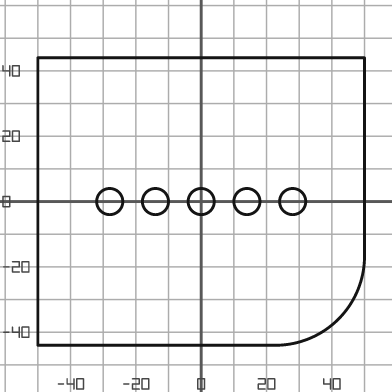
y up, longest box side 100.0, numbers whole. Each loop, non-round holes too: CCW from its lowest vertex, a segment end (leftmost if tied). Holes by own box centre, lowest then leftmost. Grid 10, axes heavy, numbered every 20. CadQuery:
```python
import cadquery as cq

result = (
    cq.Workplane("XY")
    .moveTo(-50.0, -44.0)
    .lineTo(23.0, -44.0)
    .threePointArc((42.0, -36.0), (50.0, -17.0))
    .lineTo(50.0, 44.0)
    .lineTo(-50.0, 44.0)
    .close()
    .moveTo(-28.0, 0.0)
    .circle(4.0)
    .moveTo(-14.0, 0.0)
    .circle(4.0)
    .moveTo(0.0, 0.0)
    .circle(4.0)
    .moveTo(14.0, 0.0)
    .circle(4.0)
    .moveTo(28.0, 0.0)
    .circle(4.0)
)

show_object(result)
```